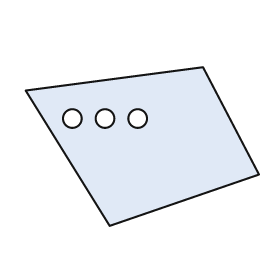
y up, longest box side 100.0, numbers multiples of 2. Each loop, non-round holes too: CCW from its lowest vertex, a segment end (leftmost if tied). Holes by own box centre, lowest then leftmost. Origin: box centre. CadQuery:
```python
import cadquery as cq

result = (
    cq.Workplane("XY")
    .moveTo(-14.0, -34.0)
    .lineTo(50.0, -12.0)
    .lineTo(26.0, 34.0)
    .lineTo(-50.0, 24.0)
    .close()
    .moveTo(-30.0, 12.0)
    .circle(4.0)
    .moveTo(-16.0, 12.0)
    .circle(4.0)
    .moveTo(-2.0, 12.0)
    .circle(4.0)
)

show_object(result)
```